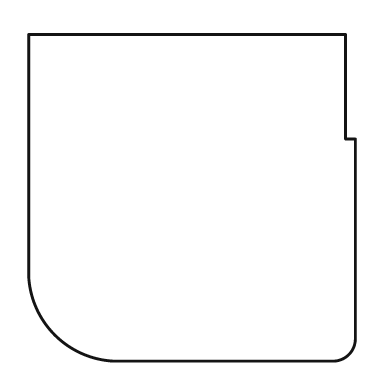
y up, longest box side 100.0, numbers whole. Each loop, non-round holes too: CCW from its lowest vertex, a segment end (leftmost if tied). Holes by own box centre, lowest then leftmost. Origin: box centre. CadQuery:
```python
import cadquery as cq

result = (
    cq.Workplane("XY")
    .moveTo(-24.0, -50.0)
    .lineTo(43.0, -50.0)
    .threePointArc((48.0, -48.0), (50.0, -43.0))
    .lineTo(50.0, 18.0)
    .lineTo(47.0, 18.0)
    .lineTo(47.0, 50.0)
    .lineTo(-50.0, 50.0)
    .lineTo(-50.0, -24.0)
    .threePointArc((-42.0, -42.0), (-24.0, -50.0))
    .close()
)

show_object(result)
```